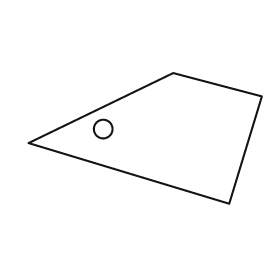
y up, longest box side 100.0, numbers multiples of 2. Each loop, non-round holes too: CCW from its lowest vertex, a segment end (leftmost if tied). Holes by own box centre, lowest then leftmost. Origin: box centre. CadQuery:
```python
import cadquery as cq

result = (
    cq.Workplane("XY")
    .moveTo(36.0, -28.0)
    .lineTo(50.0, 18.0)
    .lineTo(12.0, 28.0)
    .lineTo(-50.0, -2.0)
    .close()
    .moveTo(-18.0, 4.0)
    .circle(4.0)
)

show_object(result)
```